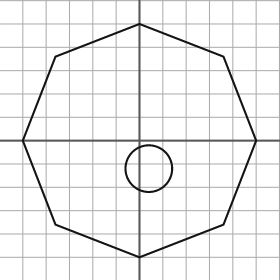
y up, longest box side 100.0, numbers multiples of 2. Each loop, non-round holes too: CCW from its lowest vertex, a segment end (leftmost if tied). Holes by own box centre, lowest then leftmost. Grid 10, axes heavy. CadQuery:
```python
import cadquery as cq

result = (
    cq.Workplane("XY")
    .moveTo(0.0, -50.0)
    .lineTo(36.0, -36.0)
    .lineTo(50.0, 0.0)
    .lineTo(36.0, 36.0)
    .lineTo(0.0, 50.0)
    .lineTo(-36.0, 36.0)
    .lineTo(-50.0, 0.0)
    .lineTo(-36.0, -36.0)
    .close()
    .moveTo(4.0, -12.0)
    .circle(10.0)
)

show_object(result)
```